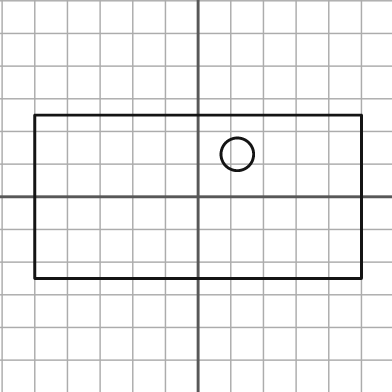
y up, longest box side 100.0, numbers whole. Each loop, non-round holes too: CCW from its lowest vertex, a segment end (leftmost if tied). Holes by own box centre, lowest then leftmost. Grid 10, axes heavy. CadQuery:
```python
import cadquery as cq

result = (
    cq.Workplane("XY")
    .moveTo(-50.0, -25.0)
    .lineTo(50.0, -25.0)
    .lineTo(50.0, 25.0)
    .lineTo(-50.0, 25.0)
    .close()
    .moveTo(12.0, 13.0)
    .circle(5.0)
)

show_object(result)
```